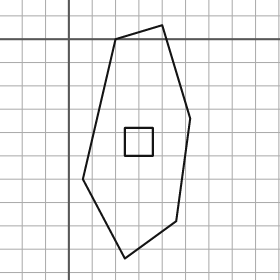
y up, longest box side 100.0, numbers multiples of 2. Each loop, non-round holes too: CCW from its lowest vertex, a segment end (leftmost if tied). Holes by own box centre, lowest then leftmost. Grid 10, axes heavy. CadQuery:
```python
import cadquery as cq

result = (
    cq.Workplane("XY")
    .moveTo(24.0, -94.0)
    .lineTo(46.0, -78.0)
    .lineTo(52.0, -34.0)
    .lineTo(40.0, 6.0)
    .lineTo(20.0, 0.0)
    .lineTo(6.0, -60.0)
    .close()
    .moveTo(24.0, -50.0)
    .lineTo(36.0, -50.0)
    .lineTo(36.0, -38.0)
    .lineTo(24.0, -38.0)
    .close()
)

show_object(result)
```